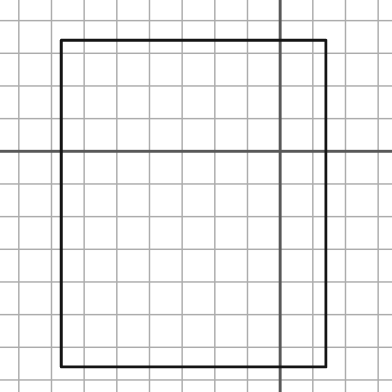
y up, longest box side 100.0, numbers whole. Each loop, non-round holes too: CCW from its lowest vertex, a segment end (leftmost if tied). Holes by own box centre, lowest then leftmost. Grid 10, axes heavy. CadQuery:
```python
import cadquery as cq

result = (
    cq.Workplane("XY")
    .moveTo(-67.0, -66.0)
    .lineTo(14.0, -66.0)
    .lineTo(14.0, 34.0)
    .lineTo(-67.0, 34.0)
    .close()
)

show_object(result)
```